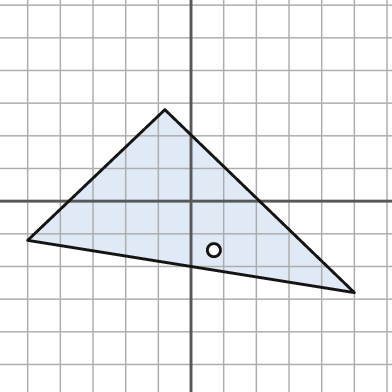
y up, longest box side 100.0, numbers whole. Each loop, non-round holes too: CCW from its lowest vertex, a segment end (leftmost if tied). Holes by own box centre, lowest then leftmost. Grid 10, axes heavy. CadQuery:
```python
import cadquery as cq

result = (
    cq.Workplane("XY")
    .moveTo(50.0, -28.0)
    .lineTo(-8.0, 28.0)
    .lineTo(-50.0, -12.0)
    .close()
    .moveTo(7.0, -15.0)
    .circle(2.0)
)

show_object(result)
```